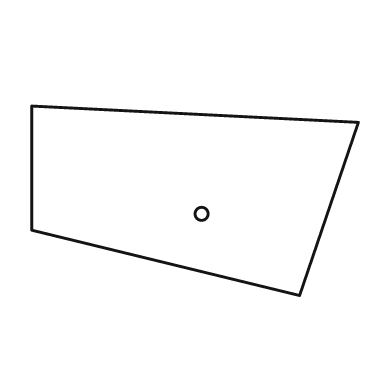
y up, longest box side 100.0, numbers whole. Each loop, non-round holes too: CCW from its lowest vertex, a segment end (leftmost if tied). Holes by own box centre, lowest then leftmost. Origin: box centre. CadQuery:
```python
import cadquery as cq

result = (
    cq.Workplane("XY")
    .moveTo(32.0, -29.0)
    .lineTo(50.0, 24.0)
    .lineTo(-50.0, 29.0)
    .lineTo(-50.0, -9.0)
    .close()
    .moveTo(2.0, -4.0)
    .circle(2.0)
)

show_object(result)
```